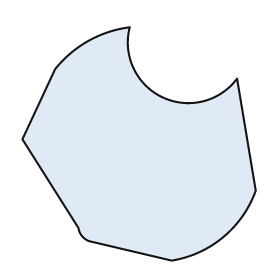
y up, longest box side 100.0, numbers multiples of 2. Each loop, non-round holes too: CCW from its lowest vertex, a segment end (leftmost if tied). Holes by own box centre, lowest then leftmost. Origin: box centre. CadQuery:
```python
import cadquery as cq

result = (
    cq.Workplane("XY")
    .moveTo(14.0, -50.0)
    .threePointArc((36.0, -40.0), (50.0, -20.0))
    .lineTo(42.0, 28.0)
    .threePointArc((10.0, 20.0), (-4.0, 50.0))
    .threePointArc((-22.0, 44.0), (-36.0, 32.0))
    .lineTo(-50.0, 2.0)
    .lineTo(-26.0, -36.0)
    .threePointArc((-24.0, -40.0), (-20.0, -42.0))
    .close()
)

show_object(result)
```